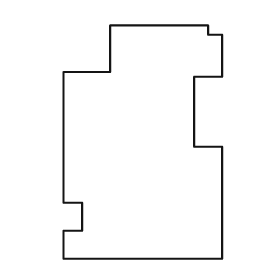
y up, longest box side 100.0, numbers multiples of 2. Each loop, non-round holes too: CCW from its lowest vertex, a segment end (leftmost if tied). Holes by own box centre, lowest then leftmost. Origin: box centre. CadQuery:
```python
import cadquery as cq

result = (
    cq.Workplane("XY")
    .moveTo(-34.0, -50.0)
    .lineTo(34.0, -50.0)
    .lineTo(34.0, -2.0)
    .lineTo(22.0, -2.0)
    .lineTo(22.0, 28.0)
    .lineTo(34.0, 28.0)
    .lineTo(34.0, 46.0)
    .lineTo(28.0, 46.0)
    .lineTo(28.0, 50.0)
    .lineTo(-14.0, 50.0)
    .lineTo(-14.0, 30.0)
    .lineTo(-34.0, 30.0)
    .lineTo(-34.0, -26.0)
    .lineTo(-26.0, -26.0)
    .lineTo(-26.0, -38.0)
    .lineTo(-34.0, -38.0)
    .close()
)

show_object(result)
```